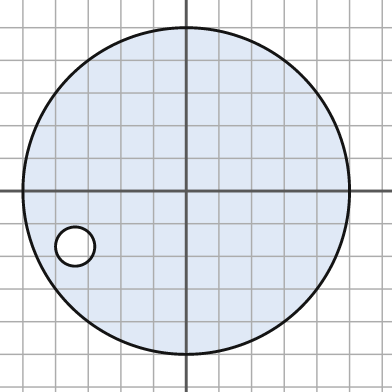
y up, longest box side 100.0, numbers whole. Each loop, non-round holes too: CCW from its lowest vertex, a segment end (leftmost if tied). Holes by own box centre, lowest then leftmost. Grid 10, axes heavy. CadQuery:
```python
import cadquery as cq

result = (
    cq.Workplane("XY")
    .moveTo(0.0, 0.0)
    .circle(50.0)
    .moveTo(-34.0, -17.0)
    .circle(6.0)
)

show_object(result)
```